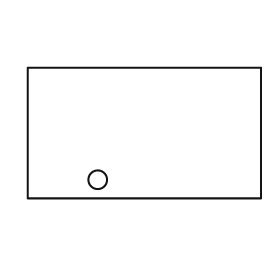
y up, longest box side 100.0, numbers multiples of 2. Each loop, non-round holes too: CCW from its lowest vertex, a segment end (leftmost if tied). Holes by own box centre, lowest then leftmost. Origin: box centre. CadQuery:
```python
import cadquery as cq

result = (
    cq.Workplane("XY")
    .moveTo(-50.0, -28.0)
    .lineTo(50.0, -28.0)
    .lineTo(50.0, 28.0)
    .lineTo(-50.0, 28.0)
    .close()
    .moveTo(-20.0, -20.0)
    .circle(4.0)
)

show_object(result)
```